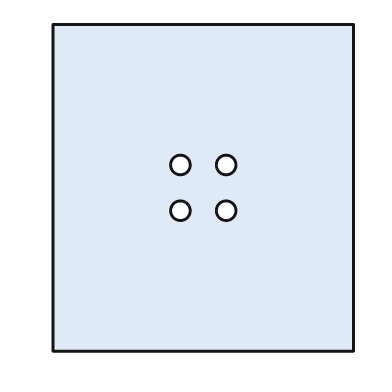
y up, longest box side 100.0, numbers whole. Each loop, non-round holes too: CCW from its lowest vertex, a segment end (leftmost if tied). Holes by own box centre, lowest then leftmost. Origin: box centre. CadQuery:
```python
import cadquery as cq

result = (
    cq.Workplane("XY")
    .moveTo(-46.0, -50.0)
    .lineTo(46.0, -50.0)
    .lineTo(46.0, 50.0)
    .lineTo(-46.0, 50.0)
    .close()
    .moveTo(-7.0, -7.0)
    .circle(3.0)
    .moveTo(7.0, -7.0)
    .circle(3.0)
    .moveTo(-7.0, 7.0)
    .circle(3.0)
    .moveTo(7.0, 7.0)
    .circle(3.0)
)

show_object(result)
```